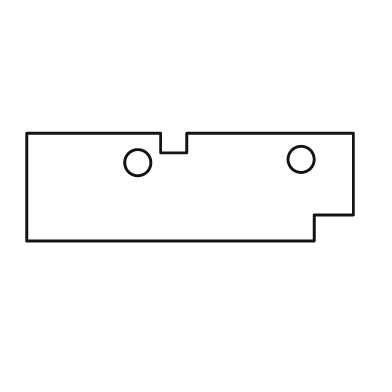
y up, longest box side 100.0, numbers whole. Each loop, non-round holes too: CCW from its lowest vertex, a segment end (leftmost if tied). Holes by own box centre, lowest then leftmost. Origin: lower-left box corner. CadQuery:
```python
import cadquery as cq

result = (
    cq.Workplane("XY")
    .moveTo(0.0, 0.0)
    .lineTo(88.0, 0.0)
    .lineTo(88.0, 8.0)
    .lineTo(100.0, 8.0)
    .lineTo(100.0, 33.0)
    .lineTo(49.0, 33.0)
    .lineTo(49.0, 27.0)
    .lineTo(41.0, 27.0)
    .lineTo(41.0, 33.0)
    .lineTo(0.0, 33.0)
    .close()
    .moveTo(34.0, 24.0)
    .circle(4.0)
    .moveTo(84.0, 25.0)
    .circle(4.0)
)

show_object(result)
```